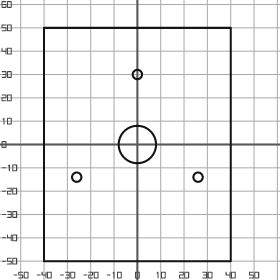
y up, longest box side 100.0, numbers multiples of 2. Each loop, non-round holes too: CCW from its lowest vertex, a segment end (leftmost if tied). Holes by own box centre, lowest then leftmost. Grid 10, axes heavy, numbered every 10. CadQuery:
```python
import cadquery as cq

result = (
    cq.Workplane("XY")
    .moveTo(-40.0, -50.0)
    .lineTo(40.0, -50.0)
    .lineTo(40.0, 50.0)
    .lineTo(-40.0, 50.0)
    .close()
    .moveTo(-26.0, -14.0)
    .circle(2.0)
    .moveTo(26.0, -14.0)
    .circle(2.0)
    .moveTo(0.0, 0.0)
    .circle(8.0)
    .moveTo(0.0, 30.0)
    .circle(2.0)
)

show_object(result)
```